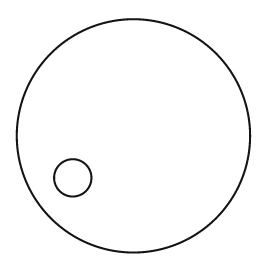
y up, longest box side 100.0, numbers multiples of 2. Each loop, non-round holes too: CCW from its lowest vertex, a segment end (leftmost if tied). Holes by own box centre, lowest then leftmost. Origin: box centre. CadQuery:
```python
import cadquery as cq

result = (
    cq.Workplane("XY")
    .moveTo(0.0, 0.0)
    .circle(50.0)
    .moveTo(-26.0, -18.0)
    .circle(8.0)
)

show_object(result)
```